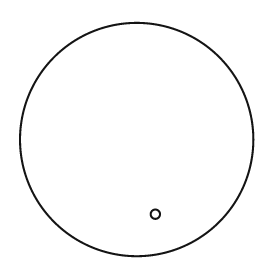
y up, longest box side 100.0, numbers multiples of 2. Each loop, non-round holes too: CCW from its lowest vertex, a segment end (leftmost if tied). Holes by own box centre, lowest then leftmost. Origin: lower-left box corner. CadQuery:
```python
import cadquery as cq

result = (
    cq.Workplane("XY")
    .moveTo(50.0, 50.0)
    .circle(50.0)
    .moveTo(58.0, 18.0)
    .circle(2.0)
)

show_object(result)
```